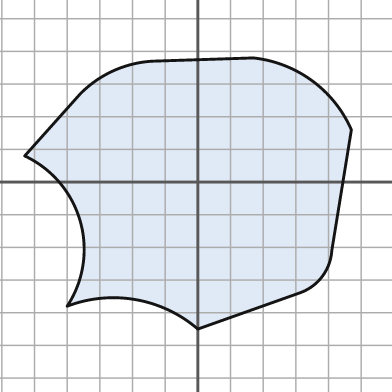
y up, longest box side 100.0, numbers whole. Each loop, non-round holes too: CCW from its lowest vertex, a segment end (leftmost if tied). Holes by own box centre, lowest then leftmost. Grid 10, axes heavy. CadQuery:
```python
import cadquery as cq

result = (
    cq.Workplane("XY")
    .moveTo(0.0, -45.0)
    .lineTo(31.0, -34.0)
    .threePointArc((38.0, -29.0), (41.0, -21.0))
    .lineTo(47.0, 16.0)
    .threePointArc((35.0, 31.0), (17.0, 38.0))
    .lineTo(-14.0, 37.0)
    .threePointArc((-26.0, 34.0), (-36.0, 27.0))
    .lineTo(-53.0, 8.0)
    .threePointArc((-36.0, -12.0), (-40.0, -38.0))
    .threePointArc((-19.0, -36.0), (0.0, -45.0))
    .close()
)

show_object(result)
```